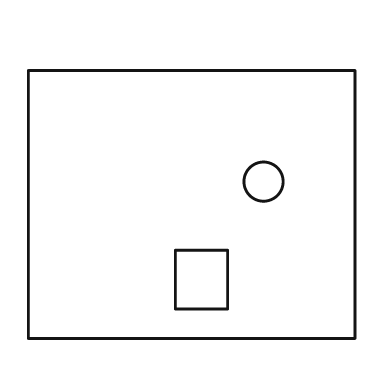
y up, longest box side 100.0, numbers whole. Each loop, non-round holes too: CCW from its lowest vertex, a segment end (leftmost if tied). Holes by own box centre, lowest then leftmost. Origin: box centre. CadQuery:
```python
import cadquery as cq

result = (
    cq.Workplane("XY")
    .moveTo(-50.0, -41.0)
    .lineTo(50.0, -41.0)
    .lineTo(50.0, 41.0)
    .lineTo(-50.0, 41.0)
    .close()
    .moveTo(-5.0, -32.0)
    .lineTo(11.0, -32.0)
    .lineTo(11.0, -14.0)
    .lineTo(-5.0, -14.0)
    .close()
    .moveTo(22.0, 7.0)
    .circle(6.0)
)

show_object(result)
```